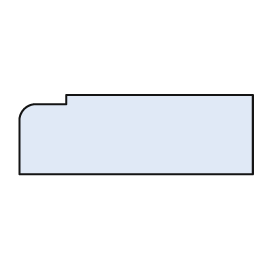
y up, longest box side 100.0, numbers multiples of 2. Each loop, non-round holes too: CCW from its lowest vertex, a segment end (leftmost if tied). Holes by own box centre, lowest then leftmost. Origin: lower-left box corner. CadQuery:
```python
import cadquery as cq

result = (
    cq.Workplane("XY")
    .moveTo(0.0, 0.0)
    .lineTo(100.0, 0.0)
    .lineTo(100.0, 34.0)
    .lineTo(20.0, 34.0)
    .lineTo(20.0, 30.0)
    .lineTo(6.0, 30.0)
    .threePointArc((2.0, 28.0), (0.0, 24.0))
    .close()
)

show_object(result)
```